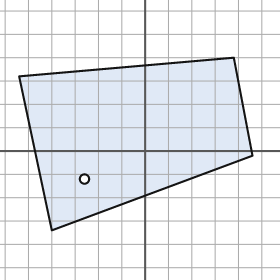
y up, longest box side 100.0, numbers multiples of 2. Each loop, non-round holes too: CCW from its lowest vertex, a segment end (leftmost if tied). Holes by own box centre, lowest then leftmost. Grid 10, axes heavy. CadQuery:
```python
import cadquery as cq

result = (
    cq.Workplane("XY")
    .moveTo(-40.0, -34.0)
    .lineTo(46.0, -2.0)
    .lineTo(38.0, 40.0)
    .lineTo(-54.0, 32.0)
    .close()
    .moveTo(-26.0, -12.0)
    .circle(2.0)
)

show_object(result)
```